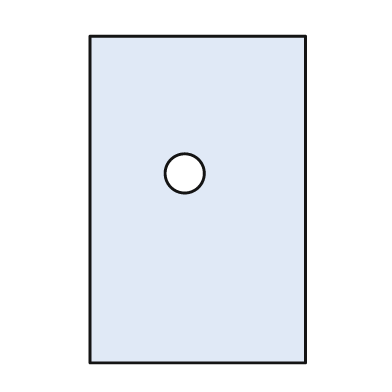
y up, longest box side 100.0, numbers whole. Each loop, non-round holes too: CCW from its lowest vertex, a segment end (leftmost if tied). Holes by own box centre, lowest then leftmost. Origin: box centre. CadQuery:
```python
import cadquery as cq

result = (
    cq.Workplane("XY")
    .moveTo(-33.0, -50.0)
    .lineTo(33.0, -50.0)
    .lineTo(33.0, 50.0)
    .lineTo(-33.0, 50.0)
    .close()
    .moveTo(-4.0, 8.0)
    .circle(6.0)
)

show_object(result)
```